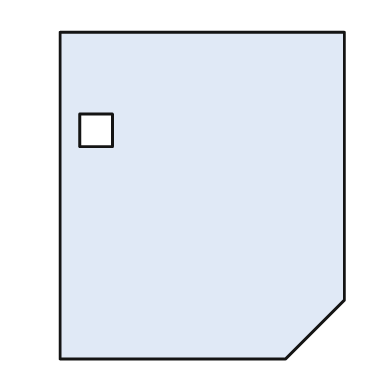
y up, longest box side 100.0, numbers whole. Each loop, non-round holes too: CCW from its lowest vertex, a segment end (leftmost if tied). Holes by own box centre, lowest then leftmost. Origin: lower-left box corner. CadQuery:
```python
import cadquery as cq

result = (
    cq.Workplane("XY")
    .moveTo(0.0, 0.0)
    .lineTo(69.0, 0.0)
    .lineTo(87.0, 18.0)
    .lineTo(87.0, 100.0)
    .lineTo(0.0, 100.0)
    .close()
    .moveTo(6.0, 65.0)
    .lineTo(16.0, 65.0)
    .lineTo(16.0, 75.0)
    .lineTo(6.0, 75.0)
    .close()
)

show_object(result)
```